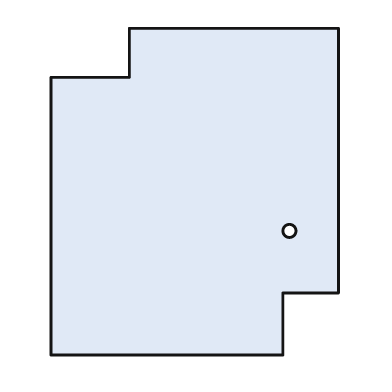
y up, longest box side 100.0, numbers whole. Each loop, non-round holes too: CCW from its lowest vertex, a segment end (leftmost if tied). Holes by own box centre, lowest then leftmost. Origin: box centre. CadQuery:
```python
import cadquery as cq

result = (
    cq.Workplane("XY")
    .moveTo(-44.0, -50.0)
    .lineTo(27.0, -50.0)
    .lineTo(27.0, -31.0)
    .lineTo(44.0, -31.0)
    .lineTo(44.0, 50.0)
    .lineTo(-20.0, 50.0)
    .lineTo(-20.0, 35.0)
    .lineTo(-44.0, 35.0)
    .close()
    .moveTo(29.0, -12.0)
    .circle(2.0)
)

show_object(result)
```